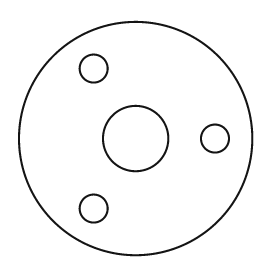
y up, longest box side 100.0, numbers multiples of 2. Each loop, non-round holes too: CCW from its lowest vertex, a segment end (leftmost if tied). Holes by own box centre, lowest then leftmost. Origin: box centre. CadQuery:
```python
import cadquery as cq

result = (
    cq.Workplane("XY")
    .moveTo(0.0, 0.0)
    .circle(50.0)
    .moveTo(-18.0, -30.0)
    .circle(6.0)
    .moveTo(0.0, 0.0)
    .circle(14.0)
    .moveTo(34.0, 0.0)
    .circle(6.0)
    .moveTo(-18.0, 30.0)
    .circle(6.0)
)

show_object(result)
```